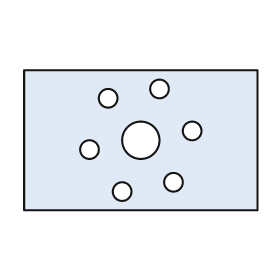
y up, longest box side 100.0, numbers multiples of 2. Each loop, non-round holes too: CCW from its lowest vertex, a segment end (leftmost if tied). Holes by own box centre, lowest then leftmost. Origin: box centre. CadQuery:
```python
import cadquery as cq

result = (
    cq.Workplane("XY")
    .moveTo(-50.0, -30.0)
    .lineTo(50.0, -30.0)
    .lineTo(50.0, 30.0)
    .lineTo(-50.0, 30.0)
    .close()
    .moveTo(-8.0, -22.0)
    .circle(4.0)
    .moveTo(14.0, -18.0)
    .circle(4.0)
    .moveTo(-22.0, -4.0)
    .circle(4.0)
    .moveTo(0.0, 0.0)
    .circle(8.0)
    .moveTo(22.0, 4.0)
    .circle(4.0)
    .moveTo(-14.0, 18.0)
    .circle(4.0)
    .moveTo(8.0, 22.0)
    .circle(4.0)
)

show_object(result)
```